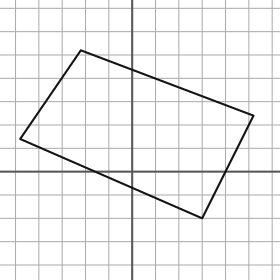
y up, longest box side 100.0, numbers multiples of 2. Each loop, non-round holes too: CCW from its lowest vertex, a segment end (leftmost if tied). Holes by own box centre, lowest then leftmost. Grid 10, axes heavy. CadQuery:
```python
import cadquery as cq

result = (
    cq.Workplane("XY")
    .moveTo(30.0, -20.0)
    .lineTo(52.0, 24.0)
    .lineTo(-22.0, 52.0)
    .lineTo(-48.0, 14.0)
    .close()
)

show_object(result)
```